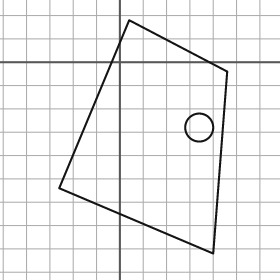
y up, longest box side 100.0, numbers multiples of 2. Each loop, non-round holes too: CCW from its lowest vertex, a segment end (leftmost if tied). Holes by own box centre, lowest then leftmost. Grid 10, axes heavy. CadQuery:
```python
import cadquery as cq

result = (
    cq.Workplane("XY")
    .moveTo(40.0, -82.0)
    .lineTo(46.0, -4.0)
    .lineTo(4.0, 18.0)
    .lineTo(-26.0, -54.0)
    .close()
    .moveTo(34.0, -28.0)
    .circle(6.0)
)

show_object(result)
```